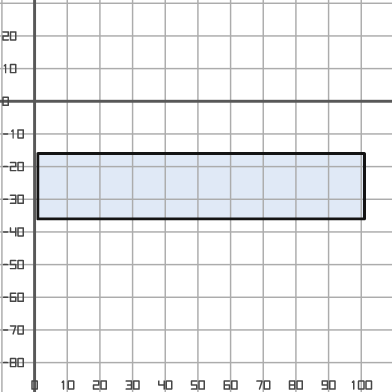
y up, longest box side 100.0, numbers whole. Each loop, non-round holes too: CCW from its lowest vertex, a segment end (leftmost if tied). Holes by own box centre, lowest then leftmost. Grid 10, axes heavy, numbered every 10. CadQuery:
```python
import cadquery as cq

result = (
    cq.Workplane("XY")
    .moveTo(1.0, -36.0)
    .lineTo(101.0, -36.0)
    .lineTo(101.0, -16.0)
    .lineTo(1.0, -16.0)
    .close()
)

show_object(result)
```